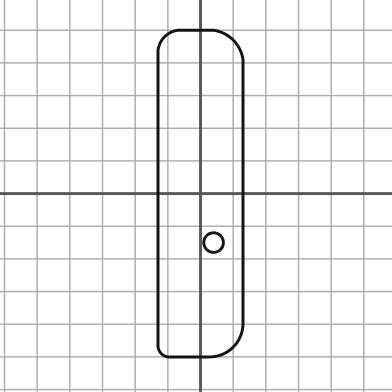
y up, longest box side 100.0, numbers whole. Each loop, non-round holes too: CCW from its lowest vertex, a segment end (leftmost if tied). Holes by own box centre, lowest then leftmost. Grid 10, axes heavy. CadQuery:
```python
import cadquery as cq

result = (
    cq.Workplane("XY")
    .moveTo(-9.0, -50.0)
    .lineTo(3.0, -50.0)
    .threePointArc((10.0, -47.0), (13.0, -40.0))
    .lineTo(13.0, 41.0)
    .threePointArc((10.0, 47.0), (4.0, 50.0))
    .lineTo(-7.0, 50.0)
    .threePointArc((-11.0, 48.0), (-13.0, 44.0))
    .lineTo(-13.0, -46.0)
    .threePointArc((-12.0, -49.0), (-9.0, -50.0))
    .close()
    .moveTo(4.0, -15.0)
    .circle(3.0)
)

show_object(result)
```